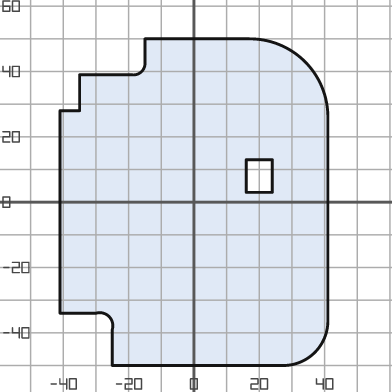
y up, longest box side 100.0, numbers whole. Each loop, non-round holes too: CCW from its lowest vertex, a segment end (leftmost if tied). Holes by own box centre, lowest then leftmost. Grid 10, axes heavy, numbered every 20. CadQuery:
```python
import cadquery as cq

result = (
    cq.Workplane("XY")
    .moveTo(-25.0, -50.0)
    .lineTo(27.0, -50.0)
    .threePointArc((37.0, -46.0), (41.0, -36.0))
    .lineTo(41.0, 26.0)
    .threePointArc((34.0, 43.0), (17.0, 50.0))
    .lineTo(-15.0, 50.0)
    .lineTo(-15.0, 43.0)
    .threePointArc((-16.0, 40.0), (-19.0, 39.0))
    .lineTo(-35.0, 39.0)
    .lineTo(-35.0, 28.0)
    .lineTo(-41.0, 28.0)
    .lineTo(-41.0, -34.0)
    .lineTo(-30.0, -34.0)
    .threePointArc((-26.0, -35.0), (-25.0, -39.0))
    .close()
    .moveTo(16.0, 3.0)
    .lineTo(24.0, 3.0)
    .lineTo(24.0, 13.0)
    .lineTo(16.0, 13.0)
    .close()
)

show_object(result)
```